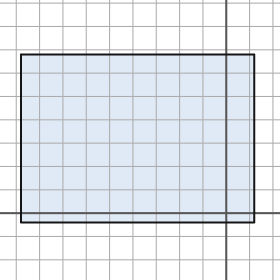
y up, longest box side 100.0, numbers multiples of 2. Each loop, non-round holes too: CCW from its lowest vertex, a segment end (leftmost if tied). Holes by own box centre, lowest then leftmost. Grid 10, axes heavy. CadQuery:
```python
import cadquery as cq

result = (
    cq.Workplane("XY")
    .moveTo(-88.0, -4.0)
    .lineTo(12.0, -4.0)
    .lineTo(12.0, 68.0)
    .lineTo(-88.0, 68.0)
    .close()
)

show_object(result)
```